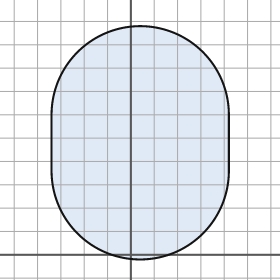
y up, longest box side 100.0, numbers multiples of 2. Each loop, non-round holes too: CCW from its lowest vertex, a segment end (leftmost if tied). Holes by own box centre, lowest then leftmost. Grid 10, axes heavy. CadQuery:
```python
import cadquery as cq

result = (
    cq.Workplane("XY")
    .moveTo(-34.0, 36.0)
    .threePointArc((4.0, -2.0), (42.0, 36.0))
    .lineTo(42.0, 60.0)
    .threePointArc((4.0, 98.0), (-34.0, 60.0))
    .close()
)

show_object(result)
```